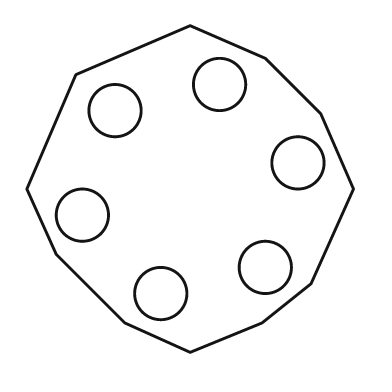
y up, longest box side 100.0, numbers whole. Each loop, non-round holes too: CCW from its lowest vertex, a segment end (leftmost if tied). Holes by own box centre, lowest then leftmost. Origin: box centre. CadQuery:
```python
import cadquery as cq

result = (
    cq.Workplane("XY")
    .moveTo(0.0, -50.0)
    .lineTo(22.0, -41.0)
    .lineTo(37.0, -29.0)
    .lineTo(50.0, 0.0)
    .lineTo(40.0, 23.0)
    .lineTo(23.0, 40.0)
    .lineTo(0.0, 50.0)
    .lineTo(-35.0, 35.0)
    .lineTo(-50.0, 0.0)
    .lineTo(-41.0, -20.0)
    .lineTo(-20.0, -41.0)
    .close()
    .moveTo(-9.0, -32.0)
    .circle(8.0)
    .moveTo(23.0, -24.0)
    .circle(8.0)
    .moveTo(-33.0, -8.0)
    .circle(8.0)
    .moveTo(33.0, 8.0)
    .circle(8.0)
    .moveTo(-23.0, 24.0)
    .circle(8.0)
    .moveTo(9.0, 32.0)
    .circle(8.0)
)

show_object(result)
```